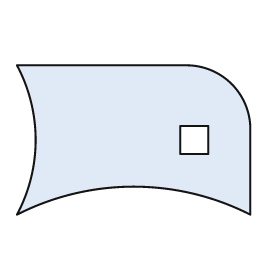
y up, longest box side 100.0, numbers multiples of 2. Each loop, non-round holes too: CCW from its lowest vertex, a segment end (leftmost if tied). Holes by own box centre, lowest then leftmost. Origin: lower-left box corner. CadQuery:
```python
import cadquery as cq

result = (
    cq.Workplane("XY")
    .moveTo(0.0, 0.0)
    .threePointArc((50.0, 12.0), (100.0, 0.0))
    .lineTo(100.0, 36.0)
    .threePointArc((92.0, 56.0), (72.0, 64.0))
    .lineTo(0.0, 64.0)
    .threePointArc((8.0, 32.0), (0.0, 0.0))
    .close()
    .moveTo(70.0, 26.0)
    .lineTo(82.0, 26.0)
    .lineTo(82.0, 38.0)
    .lineTo(70.0, 38.0)
    .close()
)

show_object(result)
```